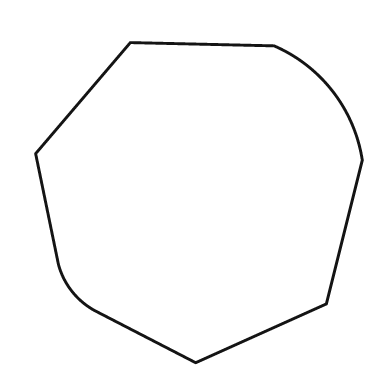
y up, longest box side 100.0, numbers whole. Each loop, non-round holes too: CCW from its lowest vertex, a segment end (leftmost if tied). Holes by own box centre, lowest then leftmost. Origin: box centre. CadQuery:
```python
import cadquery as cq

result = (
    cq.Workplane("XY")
    .moveTo(-1.0, -49.0)
    .lineTo(39.0, -31.0)
    .lineTo(50.0, 13.0)
    .threePointArc((41.0, 34.0), (23.0, 48.0))
    .lineTo(-21.0, 49.0)
    .lineTo(-50.0, 15.0)
    .lineTo(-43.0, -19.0)
    .threePointArc((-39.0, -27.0), (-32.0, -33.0))
    .close()
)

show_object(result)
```